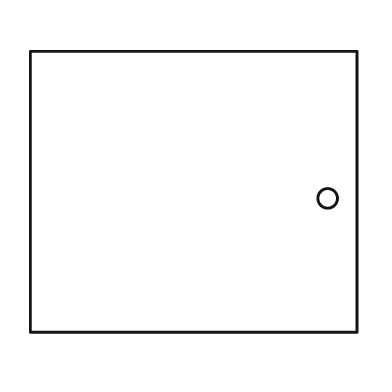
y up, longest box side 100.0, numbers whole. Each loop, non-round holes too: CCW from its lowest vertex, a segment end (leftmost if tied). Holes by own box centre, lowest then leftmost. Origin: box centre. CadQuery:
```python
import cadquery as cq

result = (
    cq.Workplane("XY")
    .moveTo(-50.0, -43.0)
    .lineTo(50.0, -43.0)
    .lineTo(50.0, 43.0)
    .lineTo(-50.0, 43.0)
    .close()
    .moveTo(41.0, -2.0)
    .circle(3.0)
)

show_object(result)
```